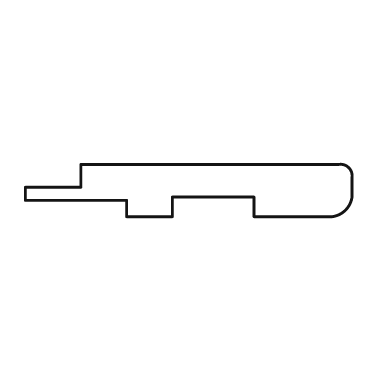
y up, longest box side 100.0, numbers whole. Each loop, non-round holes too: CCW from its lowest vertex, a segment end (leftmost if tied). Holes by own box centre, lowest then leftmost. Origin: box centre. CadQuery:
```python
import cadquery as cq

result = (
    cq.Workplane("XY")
    .moveTo(-19.0, -8.0)
    .lineTo(-5.0, -8.0)
    .lineTo(-5.0, -2.0)
    .lineTo(20.0, -2.0)
    .lineTo(20.0, -8.0)
    .lineTo(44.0, -8.0)
    .threePointArc((48.0, -6.0), (50.0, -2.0))
    .lineTo(50.0, 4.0)
    .threePointArc((49.0, 7.0), (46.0, 8.0))
    .lineTo(-33.0, 8.0)
    .lineTo(-33.0, 1.0)
    .lineTo(-50.0, 1.0)
    .lineTo(-50.0, -3.0)
    .lineTo(-19.0, -3.0)
    .close()
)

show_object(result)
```